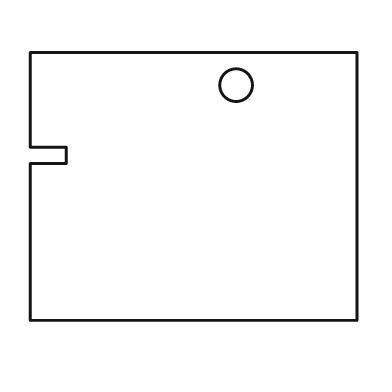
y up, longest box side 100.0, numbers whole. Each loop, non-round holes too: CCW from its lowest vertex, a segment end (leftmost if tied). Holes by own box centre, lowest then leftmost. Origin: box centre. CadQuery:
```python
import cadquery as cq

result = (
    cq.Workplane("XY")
    .moveTo(-50.0, -41.0)
    .lineTo(50.0, -41.0)
    .lineTo(50.0, 41.0)
    .lineTo(-50.0, 41.0)
    .lineTo(-50.0, 12.0)
    .lineTo(-39.0, 12.0)
    .lineTo(-39.0, 7.0)
    .lineTo(-50.0, 7.0)
    .close()
    .moveTo(13.0, 31.0)
    .circle(5.0)
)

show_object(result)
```